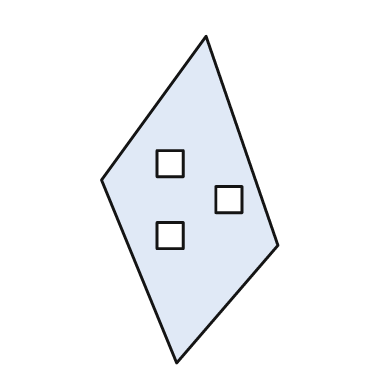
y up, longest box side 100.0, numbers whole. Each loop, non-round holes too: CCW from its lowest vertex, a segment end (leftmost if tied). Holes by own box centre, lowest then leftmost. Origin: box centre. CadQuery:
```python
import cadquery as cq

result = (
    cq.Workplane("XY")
    .moveTo(-4.0, -50.0)
    .lineTo(27.0, -14.0)
    .lineTo(5.0, 50.0)
    .lineTo(-27.0, 6.0)
    .close()
    .moveTo(-10.0, -15.0)
    .lineTo(-2.0, -15.0)
    .lineTo(-2.0, -7.0)
    .lineTo(-10.0, -7.0)
    .close()
    .moveTo(8.0, -4.0)
    .lineTo(16.0, -4.0)
    .lineTo(16.0, 4.0)
    .lineTo(8.0, 4.0)
    .close()
    .moveTo(-10.0, 7.0)
    .lineTo(-2.0, 7.0)
    .lineTo(-2.0, 15.0)
    .lineTo(-10.0, 15.0)
    .close()
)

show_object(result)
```